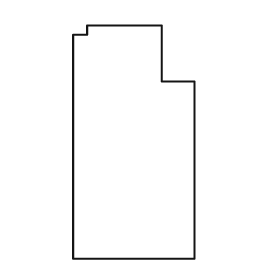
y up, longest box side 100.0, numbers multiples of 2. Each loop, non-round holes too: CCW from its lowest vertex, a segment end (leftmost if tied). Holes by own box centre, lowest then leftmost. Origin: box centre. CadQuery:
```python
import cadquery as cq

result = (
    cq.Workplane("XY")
    .moveTo(-26.0, -50.0)
    .lineTo(26.0, -50.0)
    .lineTo(26.0, 26.0)
    .lineTo(12.0, 26.0)
    .lineTo(12.0, 50.0)
    .lineTo(-20.0, 50.0)
    .lineTo(-20.0, 46.0)
    .lineTo(-26.0, 46.0)
    .close()
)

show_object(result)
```